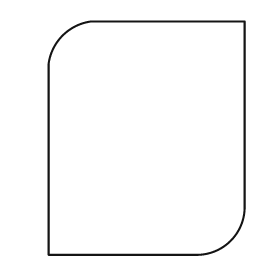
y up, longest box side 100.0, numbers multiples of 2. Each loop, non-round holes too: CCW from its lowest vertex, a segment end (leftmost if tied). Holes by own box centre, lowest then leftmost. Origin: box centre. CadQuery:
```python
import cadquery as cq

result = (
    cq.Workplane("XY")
    .moveTo(-42.0, -50.0)
    .lineTo(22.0, -50.0)
    .threePointArc((36.0, -44.0), (42.0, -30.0))
    .lineTo(42.0, 50.0)
    .lineTo(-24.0, 50.0)
    .threePointArc((-36.0, 44.0), (-42.0, 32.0))
    .close()
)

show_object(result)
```